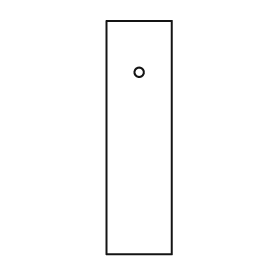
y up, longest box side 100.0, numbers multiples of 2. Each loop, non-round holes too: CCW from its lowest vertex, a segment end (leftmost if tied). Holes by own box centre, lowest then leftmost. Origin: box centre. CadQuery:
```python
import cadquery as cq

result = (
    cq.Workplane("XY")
    .moveTo(-14.0, -50.0)
    .lineTo(14.0, -50.0)
    .lineTo(14.0, 50.0)
    .lineTo(-14.0, 50.0)
    .close()
    .moveTo(0.0, 28.0)
    .circle(2.0)
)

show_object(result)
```